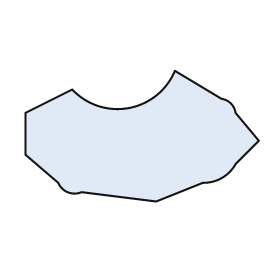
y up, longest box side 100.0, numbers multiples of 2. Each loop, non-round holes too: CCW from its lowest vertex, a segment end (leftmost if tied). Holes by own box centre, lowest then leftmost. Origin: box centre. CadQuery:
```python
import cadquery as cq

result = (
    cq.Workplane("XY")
    .moveTo(6.0, -28.0)
    .lineTo(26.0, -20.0)
    .threePointArc((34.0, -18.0), (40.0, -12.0))
    .lineTo(50.0, -2.0)
    .lineTo(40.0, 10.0)
    .threePointArc((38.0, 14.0), (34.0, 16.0))
    .lineTo(14.0, 28.0)
    .threePointArc((-6.0, 12.0), (-30.0, 20.0))
    .lineTo(-50.0, 10.0)
    .lineTo(-50.0, -8.0)
    .lineTo(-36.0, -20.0)
    .threePointArc((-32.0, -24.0), (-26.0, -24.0))
    .close()
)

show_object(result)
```